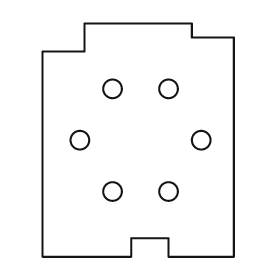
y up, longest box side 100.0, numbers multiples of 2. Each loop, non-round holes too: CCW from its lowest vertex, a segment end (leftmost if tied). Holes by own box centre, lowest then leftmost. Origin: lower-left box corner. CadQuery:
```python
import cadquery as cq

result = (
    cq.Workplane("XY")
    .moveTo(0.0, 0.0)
    .lineTo(38.0, 0.0)
    .lineTo(38.0, 8.0)
    .lineTo(54.0, 8.0)
    .lineTo(54.0, 0.0)
    .lineTo(82.0, 0.0)
    .lineTo(82.0, 94.0)
    .lineTo(64.0, 94.0)
    .lineTo(64.0, 100.0)
    .lineTo(18.0, 100.0)
    .lineTo(18.0, 88.0)
    .lineTo(0.0, 88.0)
    .close()
    .moveTo(30.0, 28.0)
    .circle(4.0)
    .moveTo(54.0, 28.0)
    .circle(4.0)
    .moveTo(16.0, 50.0)
    .circle(4.0)
    .moveTo(68.0, 50.0)
    .circle(4.0)
    .moveTo(30.0, 72.0)
    .circle(4.0)
    .moveTo(54.0, 72.0)
    .circle(4.0)
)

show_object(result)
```